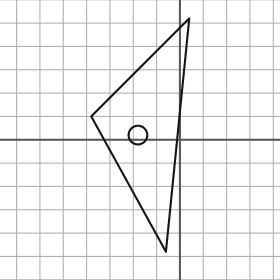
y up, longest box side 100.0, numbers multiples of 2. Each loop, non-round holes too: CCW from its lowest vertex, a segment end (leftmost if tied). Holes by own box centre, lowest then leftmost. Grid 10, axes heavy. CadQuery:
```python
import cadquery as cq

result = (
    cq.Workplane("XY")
    .moveTo(-6.0, -48.0)
    .lineTo(4.0, 52.0)
    .lineTo(-38.0, 10.0)
    .close()
    .moveTo(-18.0, 2.0)
    .circle(4.0)
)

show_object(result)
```